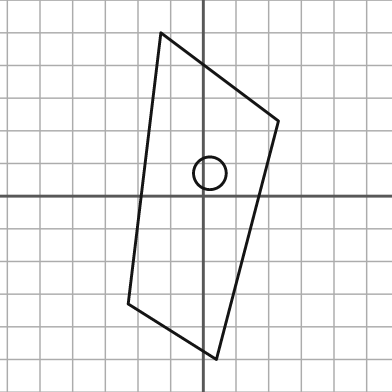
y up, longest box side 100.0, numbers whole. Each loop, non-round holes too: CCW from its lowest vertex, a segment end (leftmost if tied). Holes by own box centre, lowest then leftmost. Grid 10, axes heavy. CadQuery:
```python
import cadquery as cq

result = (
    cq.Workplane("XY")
    .moveTo(4.0, -50.0)
    .lineTo(23.0, 23.0)
    .lineTo(-13.0, 50.0)
    .lineTo(-23.0, -33.0)
    .close()
    .moveTo(2.0, 7.0)
    .circle(5.0)
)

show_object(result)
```